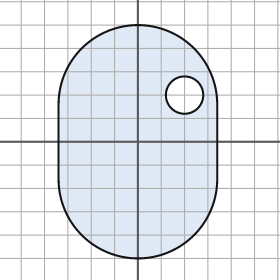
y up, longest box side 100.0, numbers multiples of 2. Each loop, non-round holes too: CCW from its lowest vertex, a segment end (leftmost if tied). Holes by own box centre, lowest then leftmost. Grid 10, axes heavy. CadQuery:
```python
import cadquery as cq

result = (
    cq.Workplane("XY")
    .moveTo(-34.0, -16.0)
    .threePointArc((0.0, -50.0), (34.0, -16.0))
    .lineTo(34.0, 16.0)
    .threePointArc((0.0, 50.0), (-34.0, 16.0))
    .close()
    .moveTo(20.0, 20.0)
    .circle(8.0)
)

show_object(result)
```